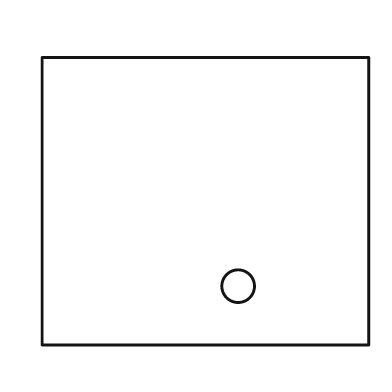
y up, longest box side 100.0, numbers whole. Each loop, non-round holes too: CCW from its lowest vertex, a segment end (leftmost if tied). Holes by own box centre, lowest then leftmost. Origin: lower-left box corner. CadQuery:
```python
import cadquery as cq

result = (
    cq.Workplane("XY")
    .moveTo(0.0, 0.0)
    .lineTo(100.0, 0.0)
    .lineTo(100.0, 88.0)
    .lineTo(0.0, 88.0)
    .close()
    .moveTo(60.0, 18.0)
    .circle(5.0)
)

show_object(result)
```